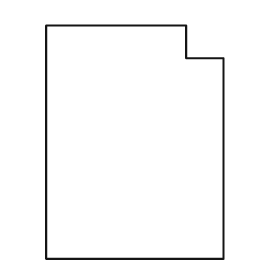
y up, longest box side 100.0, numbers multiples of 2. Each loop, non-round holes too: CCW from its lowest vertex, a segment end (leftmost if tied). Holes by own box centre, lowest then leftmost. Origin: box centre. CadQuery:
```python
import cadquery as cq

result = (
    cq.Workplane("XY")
    .moveTo(-38.0, -50.0)
    .lineTo(38.0, -50.0)
    .lineTo(38.0, 36.0)
    .lineTo(22.0, 36.0)
    .lineTo(22.0, 50.0)
    .lineTo(-38.0, 50.0)
    .close()
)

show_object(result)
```